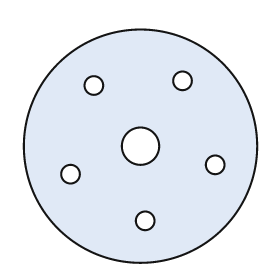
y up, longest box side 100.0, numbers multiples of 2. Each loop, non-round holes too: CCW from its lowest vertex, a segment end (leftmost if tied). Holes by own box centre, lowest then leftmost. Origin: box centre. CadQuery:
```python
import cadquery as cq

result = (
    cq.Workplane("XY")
    .moveTo(0.0, 0.0)
    .circle(50.0)
    .moveTo(2.0, -32.0)
    .circle(4.0)
    .moveTo(-30.0, -12.0)
    .circle(4.0)
    .moveTo(32.0, -8.0)
    .circle(4.0)
    .moveTo(0.0, 0.0)
    .circle(8.0)
    .moveTo(-20.0, 26.0)
    .circle(4.0)
    .moveTo(18.0, 28.0)
    .circle(4.0)
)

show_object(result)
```